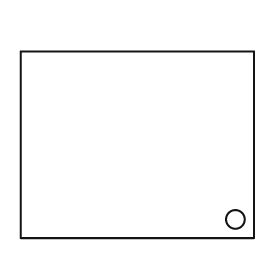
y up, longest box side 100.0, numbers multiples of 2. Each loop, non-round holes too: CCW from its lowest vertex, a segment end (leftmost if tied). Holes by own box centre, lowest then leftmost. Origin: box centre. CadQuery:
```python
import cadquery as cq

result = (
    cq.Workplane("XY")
    .moveTo(-50.0, -40.0)
    .lineTo(50.0, -40.0)
    .lineTo(50.0, 40.0)
    .lineTo(-50.0, 40.0)
    .close()
    .moveTo(42.0, -32.0)
    .circle(4.0)
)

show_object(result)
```